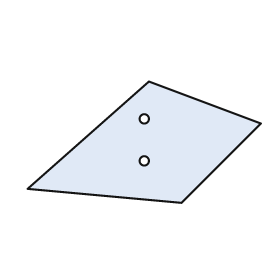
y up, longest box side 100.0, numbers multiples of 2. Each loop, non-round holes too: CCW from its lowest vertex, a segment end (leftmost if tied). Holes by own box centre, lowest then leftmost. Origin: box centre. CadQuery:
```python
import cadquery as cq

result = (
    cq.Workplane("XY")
    .moveTo(16.0, -26.0)
    .lineTo(50.0, 8.0)
    .lineTo(2.0, 26.0)
    .lineTo(-50.0, -20.0)
    .close()
    .moveTo(0.0, -8.0)
    .circle(2.0)
    .moveTo(0.0, 10.0)
    .circle(2.0)
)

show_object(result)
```